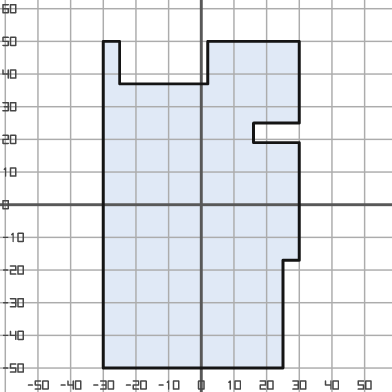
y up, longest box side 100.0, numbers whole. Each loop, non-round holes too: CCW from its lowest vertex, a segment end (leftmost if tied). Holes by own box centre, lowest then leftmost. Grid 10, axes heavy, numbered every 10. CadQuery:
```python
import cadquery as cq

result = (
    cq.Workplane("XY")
    .moveTo(-30.0, -50.0)
    .lineTo(25.0, -50.0)
    .lineTo(25.0, -17.0)
    .lineTo(30.0, -17.0)
    .lineTo(30.0, 19.0)
    .lineTo(16.0, 19.0)
    .lineTo(16.0, 25.0)
    .lineTo(30.0, 25.0)
    .lineTo(30.0, 50.0)
    .lineTo(2.0, 50.0)
    .lineTo(2.0, 37.0)
    .lineTo(-25.0, 37.0)
    .lineTo(-25.0, 50.0)
    .lineTo(-30.0, 50.0)
    .close()
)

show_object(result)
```